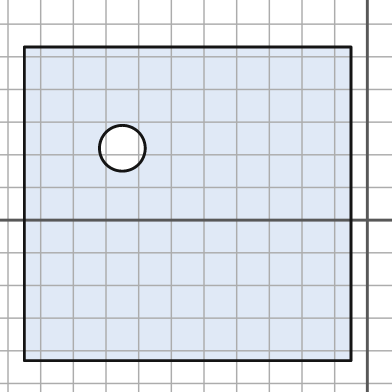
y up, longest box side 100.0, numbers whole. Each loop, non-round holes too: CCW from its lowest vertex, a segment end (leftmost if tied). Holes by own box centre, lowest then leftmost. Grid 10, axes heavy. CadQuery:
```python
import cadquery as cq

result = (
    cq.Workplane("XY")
    .moveTo(-105.0, -43.0)
    .lineTo(-5.0, -43.0)
    .lineTo(-5.0, 53.0)
    .lineTo(-105.0, 53.0)
    .close()
    .moveTo(-75.0, 22.0)
    .circle(7.0)
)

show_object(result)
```